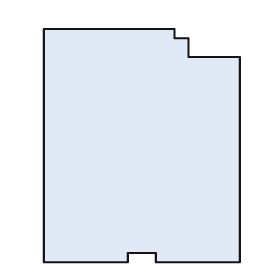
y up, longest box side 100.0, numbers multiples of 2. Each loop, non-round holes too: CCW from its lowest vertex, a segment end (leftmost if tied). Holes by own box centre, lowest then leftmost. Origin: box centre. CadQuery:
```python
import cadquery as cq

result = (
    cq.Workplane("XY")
    .moveTo(-42.0, -50.0)
    .lineTo(-6.0, -50.0)
    .lineTo(-6.0, -46.0)
    .lineTo(6.0, -46.0)
    .lineTo(6.0, -50.0)
    .lineTo(42.0, -50.0)
    .lineTo(42.0, 38.0)
    .lineTo(20.0, 38.0)
    .lineTo(20.0, 46.0)
    .lineTo(14.0, 46.0)
    .lineTo(14.0, 50.0)
    .lineTo(-42.0, 50.0)
    .close()
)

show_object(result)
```